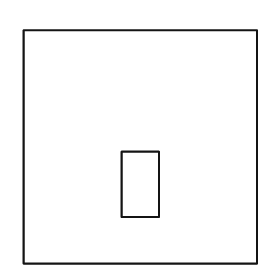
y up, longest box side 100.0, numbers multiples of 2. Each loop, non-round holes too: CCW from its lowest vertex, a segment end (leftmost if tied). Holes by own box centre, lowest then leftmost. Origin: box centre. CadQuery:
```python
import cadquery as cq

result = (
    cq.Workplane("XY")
    .moveTo(-50.0, -50.0)
    .lineTo(50.0, -50.0)
    .lineTo(50.0, 50.0)
    .lineTo(-50.0, 50.0)
    .close()
    .moveTo(-8.0, -30.0)
    .lineTo(8.0, -30.0)
    .lineTo(8.0, -2.0)
    .lineTo(-8.0, -2.0)
    .close()
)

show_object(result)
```